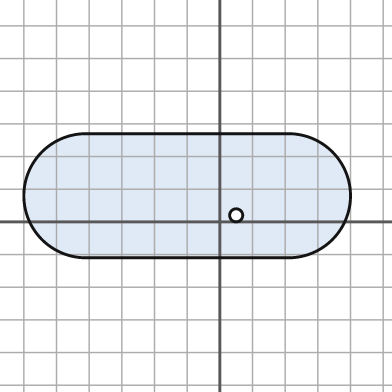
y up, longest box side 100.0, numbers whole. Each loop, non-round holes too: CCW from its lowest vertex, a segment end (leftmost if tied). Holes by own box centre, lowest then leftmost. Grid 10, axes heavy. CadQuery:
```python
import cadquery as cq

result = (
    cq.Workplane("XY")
    .moveTo(-41.0, -11.0)
    .lineTo(21.0, -11.0)
    .threePointArc((40.0, 8.0), (21.0, 27.0))
    .lineTo(-41.0, 27.0)
    .threePointArc((-60.0, 8.0), (-41.0, -11.0))
    .close()
    .moveTo(5.0, 2.0)
    .circle(2.0)
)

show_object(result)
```